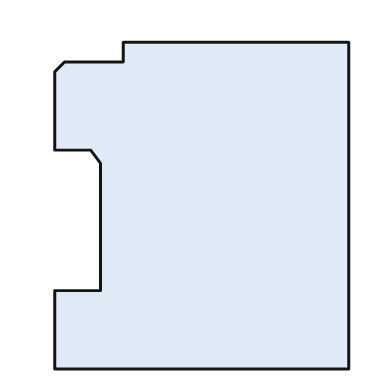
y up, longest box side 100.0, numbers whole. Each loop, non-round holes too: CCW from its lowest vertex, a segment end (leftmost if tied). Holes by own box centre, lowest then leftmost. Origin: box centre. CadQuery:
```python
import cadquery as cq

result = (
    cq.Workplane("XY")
    .moveTo(-45.0, -50.0)
    .lineTo(45.0, -50.0)
    .lineTo(45.0, 50.0)
    .lineTo(-24.0, 50.0)
    .lineTo(-24.0, 44.0)
    .lineTo(-42.0, 44.0)
    .lineTo(-45.0, 41.0)
    .lineTo(-45.0, 17.0)
    .lineTo(-34.0, 17.0)
    .lineTo(-31.0, 13.0)
    .lineTo(-31.0, -26.0)
    .lineTo(-45.0, -26.0)
    .close()
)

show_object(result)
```